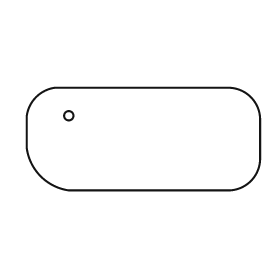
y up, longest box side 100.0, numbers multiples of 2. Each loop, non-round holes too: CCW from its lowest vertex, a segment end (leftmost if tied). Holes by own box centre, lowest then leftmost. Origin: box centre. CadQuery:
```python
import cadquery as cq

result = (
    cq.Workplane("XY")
    .moveTo(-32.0, -22.0)
    .lineTo(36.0, -22.0)
    .threePointArc((46.0, -18.0), (50.0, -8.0))
    .lineTo(50.0, 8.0)
    .threePointArc((46.0, 18.0), (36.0, 22.0))
    .lineTo(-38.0, 22.0)
    .threePointArc((-46.0, 18.0), (-50.0, 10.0))
    .lineTo(-50.0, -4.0)
    .threePointArc((-44.0, -16.0), (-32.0, -22.0))
    .close()
    .moveTo(-32.0, 10.0)
    .circle(2.0)
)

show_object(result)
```